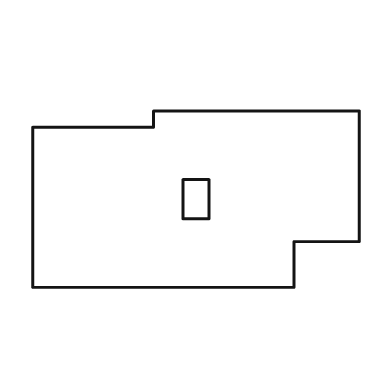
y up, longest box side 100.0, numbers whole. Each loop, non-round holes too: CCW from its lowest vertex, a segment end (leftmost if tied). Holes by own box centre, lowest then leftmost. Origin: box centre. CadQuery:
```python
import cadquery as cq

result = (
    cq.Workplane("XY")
    .moveTo(-50.0, -27.0)
    .lineTo(30.0, -27.0)
    .lineTo(30.0, -13.0)
    .lineTo(50.0, -13.0)
    .lineTo(50.0, 27.0)
    .lineTo(-13.0, 27.0)
    .lineTo(-13.0, 22.0)
    .lineTo(-50.0, 22.0)
    .close()
    .moveTo(-4.0, -6.0)
    .lineTo(4.0, -6.0)
    .lineTo(4.0, 6.0)
    .lineTo(-4.0, 6.0)
    .close()
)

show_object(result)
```